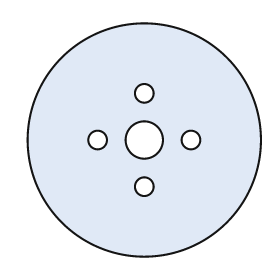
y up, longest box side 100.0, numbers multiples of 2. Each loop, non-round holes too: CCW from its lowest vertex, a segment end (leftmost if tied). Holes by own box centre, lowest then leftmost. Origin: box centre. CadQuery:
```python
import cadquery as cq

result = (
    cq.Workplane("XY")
    .moveTo(0.0, 0.0)
    .circle(50.0)
    .moveTo(0.0, -20.0)
    .circle(4.0)
    .moveTo(-20.0, 0.0)
    .circle(4.0)
    .moveTo(0.0, 0.0)
    .circle(8.0)
    .moveTo(20.0, 0.0)
    .circle(4.0)
    .moveTo(0.0, 20.0)
    .circle(4.0)
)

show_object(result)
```